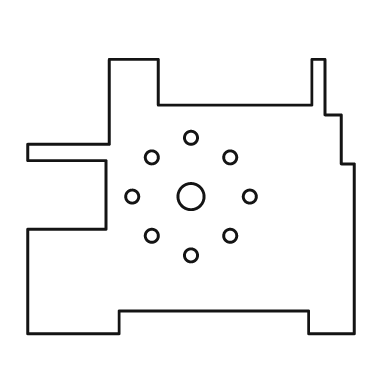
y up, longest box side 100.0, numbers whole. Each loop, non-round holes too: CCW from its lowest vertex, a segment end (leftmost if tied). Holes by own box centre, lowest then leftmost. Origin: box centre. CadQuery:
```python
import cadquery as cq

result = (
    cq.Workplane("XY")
    .moveTo(-50.0, -42.0)
    .lineTo(-22.0, -42.0)
    .lineTo(-22.0, -35.0)
    .lineTo(36.0, -35.0)
    .lineTo(36.0, -42.0)
    .lineTo(50.0, -42.0)
    .lineTo(50.0, 10.0)
    .lineTo(46.0, 10.0)
    .lineTo(46.0, 25.0)
    .lineTo(41.0, 25.0)
    .lineTo(41.0, 42.0)
    .lineTo(37.0, 42.0)
    .lineTo(37.0, 28.0)
    .lineTo(-10.0, 28.0)
    .lineTo(-10.0, 42.0)
    .lineTo(-25.0, 42.0)
    .lineTo(-25.0, 16.0)
    .lineTo(-50.0, 16.0)
    .lineTo(-50.0, 11.0)
    .lineTo(-26.0, 11.0)
    .lineTo(-26.0, -10.0)
    .lineTo(-50.0, -10.0)
    .close()
    .moveTo(0.0, -18.0)
    .circle(2.0)
    .moveTo(-12.0, -12.0)
    .circle(2.0)
    .moveTo(12.0, -12.0)
    .circle(2.0)
    .moveTo(-18.0, 0.0)
    .circle(2.0)
    .moveTo(0.0, 0.0)
    .circle(4.0)
    .moveTo(18.0, 0.0)
    .circle(2.0)
    .moveTo(-12.0, 12.0)
    .circle(2.0)
    .moveTo(12.0, 12.0)
    .circle(2.0)
    .moveTo(0.0, 18.0)
    .circle(2.0)
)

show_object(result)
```